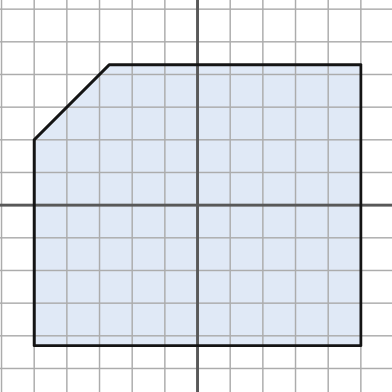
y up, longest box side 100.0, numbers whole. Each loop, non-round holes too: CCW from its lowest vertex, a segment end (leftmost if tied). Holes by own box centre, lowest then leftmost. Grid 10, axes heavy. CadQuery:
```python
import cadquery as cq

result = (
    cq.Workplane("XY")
    .moveTo(-50.0, -43.0)
    .lineTo(50.0, -43.0)
    .lineTo(50.0, 43.0)
    .lineTo(-27.0, 43.0)
    .lineTo(-50.0, 20.0)
    .close()
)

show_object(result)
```